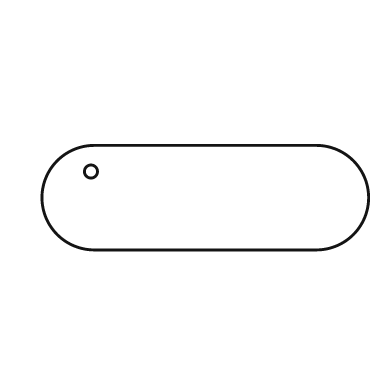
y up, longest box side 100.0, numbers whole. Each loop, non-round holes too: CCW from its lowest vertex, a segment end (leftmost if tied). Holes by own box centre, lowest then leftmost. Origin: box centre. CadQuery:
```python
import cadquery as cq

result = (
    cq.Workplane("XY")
    .moveTo(-34.0, -16.0)
    .lineTo(34.0, -16.0)
    .threePointArc((50.0, 0.0), (34.0, 16.0))
    .lineTo(-34.0, 16.0)
    .threePointArc((-50.0, 0.0), (-34.0, -16.0))
    .close()
    .moveTo(-35.0, 8.0)
    .circle(2.0)
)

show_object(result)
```